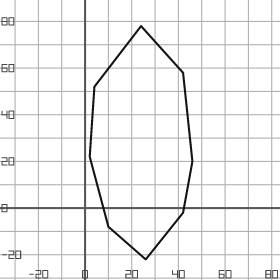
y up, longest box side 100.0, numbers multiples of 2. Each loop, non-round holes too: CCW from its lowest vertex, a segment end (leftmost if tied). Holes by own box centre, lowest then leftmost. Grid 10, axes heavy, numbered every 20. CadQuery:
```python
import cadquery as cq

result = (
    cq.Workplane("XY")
    .moveTo(26.0, -22.0)
    .lineTo(42.0, -2.0)
    .lineTo(46.0, 20.0)
    .lineTo(42.0, 58.0)
    .lineTo(24.0, 78.0)
    .lineTo(4.0, 52.0)
    .lineTo(2.0, 22.0)
    .lineTo(10.0, -8.0)
    .close()
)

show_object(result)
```